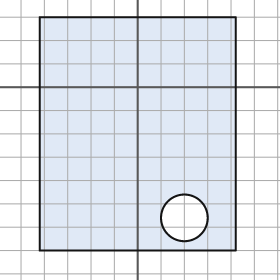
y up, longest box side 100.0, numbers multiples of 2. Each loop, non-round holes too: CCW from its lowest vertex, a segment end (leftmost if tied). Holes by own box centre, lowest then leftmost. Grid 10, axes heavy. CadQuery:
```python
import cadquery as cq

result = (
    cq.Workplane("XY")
    .moveTo(-42.0, -70.0)
    .lineTo(42.0, -70.0)
    .lineTo(42.0, 30.0)
    .lineTo(-42.0, 30.0)
    .close()
    .moveTo(20.0, -56.0)
    .circle(10.0)
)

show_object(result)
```